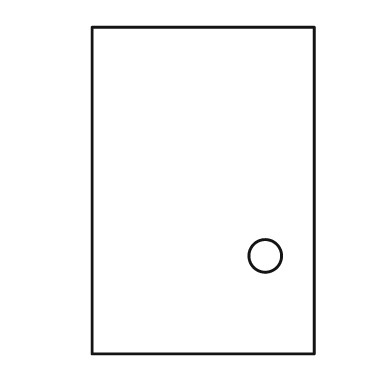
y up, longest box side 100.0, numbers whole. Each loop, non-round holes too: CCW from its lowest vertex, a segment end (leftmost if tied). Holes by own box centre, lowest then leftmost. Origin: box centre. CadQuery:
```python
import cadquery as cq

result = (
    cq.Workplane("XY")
    .moveTo(-34.0, -50.0)
    .lineTo(34.0, -50.0)
    .lineTo(34.0, 50.0)
    .lineTo(-34.0, 50.0)
    .close()
    .moveTo(19.0, -20.0)
    .circle(5.0)
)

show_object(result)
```